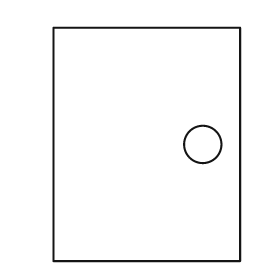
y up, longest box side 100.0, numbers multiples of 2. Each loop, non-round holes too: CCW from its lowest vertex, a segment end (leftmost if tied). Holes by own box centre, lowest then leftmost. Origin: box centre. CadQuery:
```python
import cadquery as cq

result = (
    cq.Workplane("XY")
    .moveTo(-40.0, -50.0)
    .lineTo(40.0, -50.0)
    .lineTo(40.0, 50.0)
    .lineTo(-40.0, 50.0)
    .close()
    .moveTo(24.0, 0.0)
    .circle(8.0)
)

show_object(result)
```